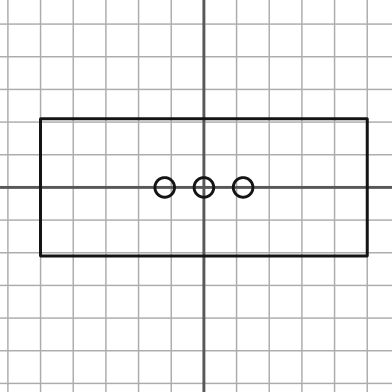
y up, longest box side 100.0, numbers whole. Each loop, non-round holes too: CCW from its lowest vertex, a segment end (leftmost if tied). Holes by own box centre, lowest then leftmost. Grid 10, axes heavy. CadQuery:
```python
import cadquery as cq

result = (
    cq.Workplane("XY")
    .moveTo(-50.0, -21.0)
    .lineTo(50.0, -21.0)
    .lineTo(50.0, 21.0)
    .lineTo(-50.0, 21.0)
    .close()
    .moveTo(-12.0, 0.0)
    .circle(3.0)
    .moveTo(0.0, 0.0)
    .circle(3.0)
    .moveTo(12.0, 0.0)
    .circle(3.0)
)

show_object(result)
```